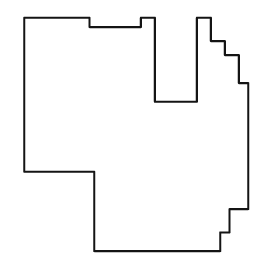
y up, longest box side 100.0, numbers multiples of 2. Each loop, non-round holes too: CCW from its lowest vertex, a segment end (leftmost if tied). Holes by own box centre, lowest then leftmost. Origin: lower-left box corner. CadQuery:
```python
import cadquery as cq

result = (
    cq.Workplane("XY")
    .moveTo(30.0, 0.0)
    .lineTo(84.0, 0.0)
    .lineTo(84.0, 8.0)
    .lineTo(88.0, 8.0)
    .lineTo(88.0, 18.0)
    .lineTo(96.0, 18.0)
    .lineTo(96.0, 72.0)
    .lineTo(92.0, 72.0)
    .lineTo(92.0, 84.0)
    .lineTo(86.0, 84.0)
    .lineTo(86.0, 90.0)
    .lineTo(80.0, 90.0)
    .lineTo(80.0, 100.0)
    .lineTo(74.0, 100.0)
    .lineTo(74.0, 64.0)
    .lineTo(56.0, 64.0)
    .lineTo(56.0, 100.0)
    .lineTo(50.0, 100.0)
    .lineTo(50.0, 96.0)
    .lineTo(28.0, 96.0)
    .lineTo(28.0, 100.0)
    .lineTo(0.0, 100.0)
    .lineTo(0.0, 34.0)
    .lineTo(30.0, 34.0)
    .close()
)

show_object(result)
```